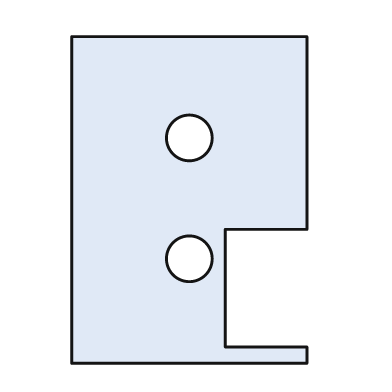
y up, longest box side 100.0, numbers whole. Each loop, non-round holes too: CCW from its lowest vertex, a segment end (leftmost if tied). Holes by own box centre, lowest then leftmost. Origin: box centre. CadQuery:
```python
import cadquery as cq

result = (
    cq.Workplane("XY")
    .moveTo(-36.0, -50.0)
    .lineTo(36.0, -50.0)
    .lineTo(36.0, -45.0)
    .lineTo(11.0, -45.0)
    .lineTo(11.0, -9.0)
    .lineTo(36.0, -9.0)
    .lineTo(36.0, 50.0)
    .lineTo(-36.0, 50.0)
    .close()
    .moveTo(0.0, -18.0)
    .circle(7.0)
    .moveTo(0.0, 19.0)
    .circle(7.0)
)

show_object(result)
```